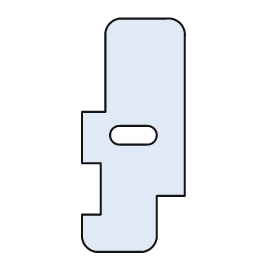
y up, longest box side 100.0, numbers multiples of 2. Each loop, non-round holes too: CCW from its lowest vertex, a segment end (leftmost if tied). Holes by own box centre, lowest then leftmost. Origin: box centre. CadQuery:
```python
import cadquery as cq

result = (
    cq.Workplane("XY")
    .moveTo(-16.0, -50.0)
    .lineTo(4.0, -50.0)
    .threePointArc((8.0, -48.0), (10.0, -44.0))
    .lineTo(10.0, -26.0)
    .lineTo(22.0, -26.0)
    .lineTo(22.0, 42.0)
    .threePointArc((20.0, 48.0), (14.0, 50.0))
    .lineTo(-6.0, 50.0)
    .threePointArc((-10.0, 48.0), (-12.0, 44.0))
    .lineTo(-12.0, 10.0)
    .lineTo(-22.0, 10.0)
    .lineTo(-22.0, -12.0)
    .lineTo(-14.0, -12.0)
    .lineTo(-14.0, -34.0)
    .lineTo(-22.0, -34.0)
    .lineTo(-22.0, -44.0)
    .threePointArc((-20.0, -48.0), (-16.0, -50.0))
    .close()
    .moveTo(-6.0, -4.0)
    .lineTo(6.0, -4.0)
    .threePointArc((10.0, 0.0), (6.0, 4.0))
    .lineTo(-6.0, 4.0)
    .threePointArc((-10.0, 0.0), (-6.0, -4.0))
    .close()
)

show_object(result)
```